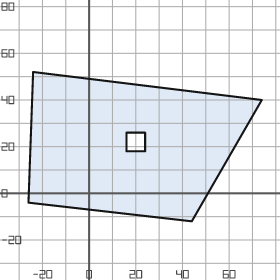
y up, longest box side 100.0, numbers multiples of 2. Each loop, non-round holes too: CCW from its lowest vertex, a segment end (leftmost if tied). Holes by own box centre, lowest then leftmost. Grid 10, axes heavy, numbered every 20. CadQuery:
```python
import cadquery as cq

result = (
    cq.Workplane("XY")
    .moveTo(44.0, -12.0)
    .lineTo(74.0, 40.0)
    .lineTo(-24.0, 52.0)
    .lineTo(-26.0, -4.0)
    .close()
    .moveTo(16.0, 18.0)
    .lineTo(24.0, 18.0)
    .lineTo(24.0, 26.0)
    .lineTo(16.0, 26.0)
    .close()
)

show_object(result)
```